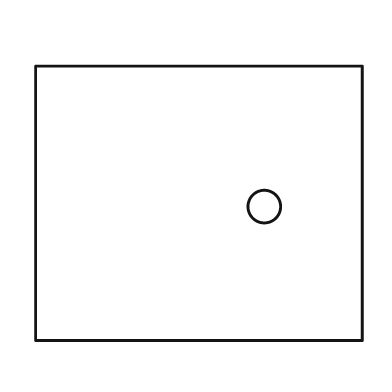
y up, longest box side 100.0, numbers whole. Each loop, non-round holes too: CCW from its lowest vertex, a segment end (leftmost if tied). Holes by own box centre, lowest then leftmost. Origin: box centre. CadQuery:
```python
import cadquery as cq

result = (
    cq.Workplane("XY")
    .moveTo(-50.0, -42.0)
    .lineTo(50.0, -42.0)
    .lineTo(50.0, 42.0)
    .lineTo(-50.0, 42.0)
    .close()
    .moveTo(20.0, -1.0)
    .circle(5.0)
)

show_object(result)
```